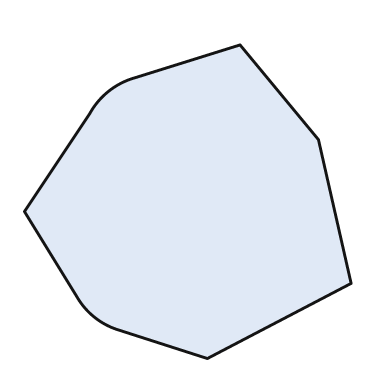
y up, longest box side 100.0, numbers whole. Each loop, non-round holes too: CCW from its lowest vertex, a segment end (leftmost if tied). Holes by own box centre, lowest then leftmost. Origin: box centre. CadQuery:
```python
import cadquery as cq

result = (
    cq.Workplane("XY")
    .moveTo(6.0, -48.0)
    .lineTo(50.0, -25.0)
    .lineTo(40.0, 19.0)
    .lineTo(16.0, 48.0)
    .lineTo(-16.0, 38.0)
    .threePointArc((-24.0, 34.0), (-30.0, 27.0))
    .lineTo(-50.0, -3.0)
    .lineTo(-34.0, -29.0)
    .threePointArc((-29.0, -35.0), (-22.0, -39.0))
    .close()
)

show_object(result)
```